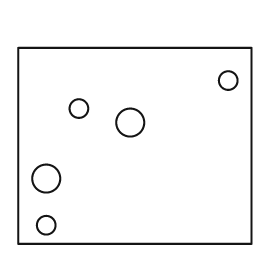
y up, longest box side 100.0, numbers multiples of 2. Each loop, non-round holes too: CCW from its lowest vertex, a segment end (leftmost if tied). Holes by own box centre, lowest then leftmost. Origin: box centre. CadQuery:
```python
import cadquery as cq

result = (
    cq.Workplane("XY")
    .moveTo(-50.0, -42.0)
    .lineTo(50.0, -42.0)
    .lineTo(50.0, 42.0)
    .lineTo(-50.0, 42.0)
    .close()
    .moveTo(-38.0, -34.0)
    .circle(4.0)
    .moveTo(-38.0, -14.0)
    .circle(6.0)
    .moveTo(-2.0, 10.0)
    .circle(6.0)
    .moveTo(-24.0, 16.0)
    .circle(4.0)
    .moveTo(40.0, 28.0)
    .circle(4.0)
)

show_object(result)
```